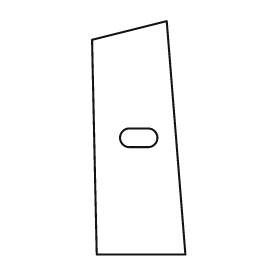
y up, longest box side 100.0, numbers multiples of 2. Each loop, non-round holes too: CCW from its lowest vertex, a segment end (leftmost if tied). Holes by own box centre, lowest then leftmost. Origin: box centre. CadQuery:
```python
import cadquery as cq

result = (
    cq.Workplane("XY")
    .moveTo(-18.0, -50.0)
    .lineTo(20.0, -50.0)
    .lineTo(12.0, 50.0)
    .lineTo(-20.0, 42.0)
    .close()
    .moveTo(-4.0, -4.0)
    .lineTo(4.0, -4.0)
    .threePointArc((8.0, 0.0), (4.0, 4.0))
    .lineTo(-4.0, 4.0)
    .threePointArc((-8.0, 0.0), (-4.0, -4.0))
    .close()
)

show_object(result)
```